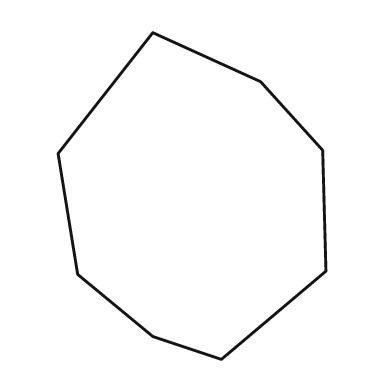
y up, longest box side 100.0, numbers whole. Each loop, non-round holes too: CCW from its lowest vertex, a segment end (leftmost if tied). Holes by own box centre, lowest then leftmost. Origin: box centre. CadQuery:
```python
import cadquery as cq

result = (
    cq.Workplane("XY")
    .moveTo(9.0, -50.0)
    .lineTo(41.0, -23.0)
    .lineTo(40.0, 14.0)
    .lineTo(21.0, 35.0)
    .lineTo(-12.0, 50.0)
    .lineTo(-41.0, 13.0)
    .lineTo(-35.0, -24.0)
    .lineTo(-12.0, -43.0)
    .close()
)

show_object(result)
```